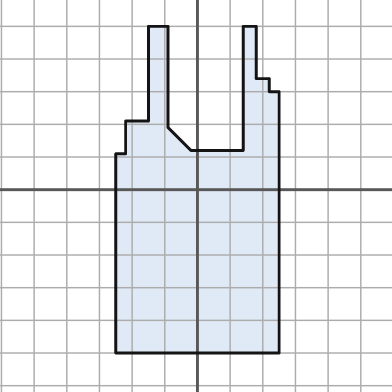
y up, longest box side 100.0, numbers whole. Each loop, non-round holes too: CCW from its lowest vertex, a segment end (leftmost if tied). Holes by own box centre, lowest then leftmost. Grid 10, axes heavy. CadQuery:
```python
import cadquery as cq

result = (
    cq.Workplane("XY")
    .moveTo(-25.0, -50.0)
    .lineTo(25.0, -50.0)
    .lineTo(25.0, 30.0)
    .lineTo(22.0, 30.0)
    .lineTo(22.0, 34.0)
    .lineTo(18.0, 34.0)
    .lineTo(18.0, 50.0)
    .lineTo(14.0, 50.0)
    .lineTo(14.0, 12.0)
    .lineTo(-2.0, 12.0)
    .lineTo(-9.0, 19.0)
    .lineTo(-9.0, 50.0)
    .lineTo(-15.0, 50.0)
    .lineTo(-15.0, 21.0)
    .lineTo(-22.0, 21.0)
    .lineTo(-22.0, 11.0)
    .lineTo(-25.0, 11.0)
    .close()
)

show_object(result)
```